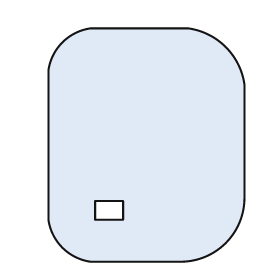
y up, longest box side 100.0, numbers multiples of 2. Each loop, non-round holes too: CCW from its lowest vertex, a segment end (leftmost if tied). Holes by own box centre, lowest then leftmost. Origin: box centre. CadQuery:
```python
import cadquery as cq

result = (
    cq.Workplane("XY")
    .moveTo(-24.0, -50.0)
    .lineTo(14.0, -50.0)
    .threePointArc((34.0, -42.0), (42.0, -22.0))
    .lineTo(42.0, 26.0)
    .threePointArc((34.0, 42.0), (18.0, 50.0))
    .lineTo(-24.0, 50.0)
    .threePointArc((-36.0, 44.0), (-42.0, 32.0))
    .lineTo(-42.0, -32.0)
    .threePointArc((-36.0, -44.0), (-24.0, -50.0))
    .close()
    .moveTo(-22.0, -32.0)
    .lineTo(-10.0, -32.0)
    .lineTo(-10.0, -24.0)
    .lineTo(-22.0, -24.0)
    .close()
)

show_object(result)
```